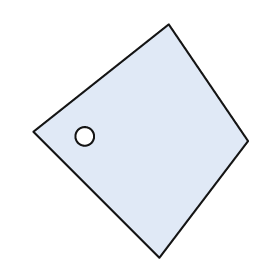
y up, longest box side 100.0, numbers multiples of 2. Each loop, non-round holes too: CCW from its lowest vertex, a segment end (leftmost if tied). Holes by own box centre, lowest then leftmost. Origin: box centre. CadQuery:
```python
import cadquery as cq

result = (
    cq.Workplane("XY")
    .moveTo(8.0, -50.0)
    .lineTo(46.0, 0.0)
    .lineTo(12.0, 50.0)
    .lineTo(-46.0, 4.0)
    .close()
    .moveTo(-24.0, 2.0)
    .circle(4.0)
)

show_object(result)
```